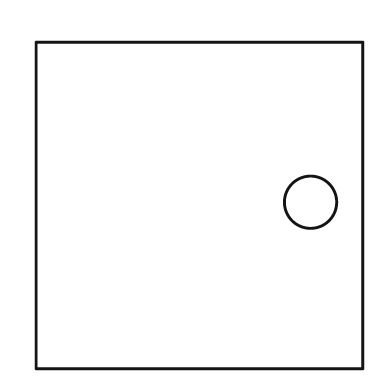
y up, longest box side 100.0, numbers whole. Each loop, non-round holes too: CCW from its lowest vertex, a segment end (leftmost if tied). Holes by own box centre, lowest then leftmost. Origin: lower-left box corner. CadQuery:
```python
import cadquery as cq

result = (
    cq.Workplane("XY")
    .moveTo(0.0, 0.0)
    .lineTo(100.0, 0.0)
    .lineTo(100.0, 100.0)
    .lineTo(0.0, 100.0)
    .close()
    .moveTo(84.0, 51.0)
    .circle(8.0)
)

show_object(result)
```